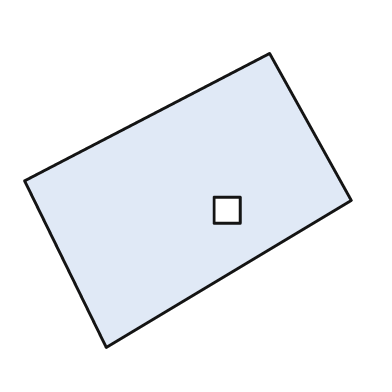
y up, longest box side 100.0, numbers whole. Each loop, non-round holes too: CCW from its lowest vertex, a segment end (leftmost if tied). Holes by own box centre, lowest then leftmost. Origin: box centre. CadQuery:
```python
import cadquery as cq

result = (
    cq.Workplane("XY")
    .moveTo(-25.0, -45.0)
    .lineTo(50.0, 0.0)
    .lineTo(25.0, 45.0)
    .lineTo(-50.0, 6.0)
    .close()
    .moveTo(8.0, -7.0)
    .lineTo(16.0, -7.0)
    .lineTo(16.0, 1.0)
    .lineTo(8.0, 1.0)
    .close()
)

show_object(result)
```